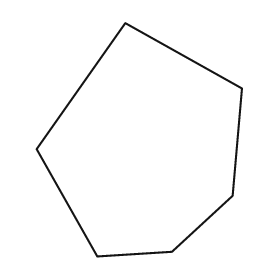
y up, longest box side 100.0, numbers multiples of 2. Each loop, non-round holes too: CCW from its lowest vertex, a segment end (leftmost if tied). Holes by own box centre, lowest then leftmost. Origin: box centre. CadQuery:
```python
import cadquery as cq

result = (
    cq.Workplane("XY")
    .moveTo(-18.0, -50.0)
    .lineTo(14.0, -48.0)
    .lineTo(40.0, -24.0)
    .lineTo(44.0, 22.0)
    .lineTo(-6.0, 50.0)
    .lineTo(-44.0, -4.0)
    .close()
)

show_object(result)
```